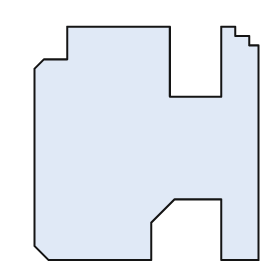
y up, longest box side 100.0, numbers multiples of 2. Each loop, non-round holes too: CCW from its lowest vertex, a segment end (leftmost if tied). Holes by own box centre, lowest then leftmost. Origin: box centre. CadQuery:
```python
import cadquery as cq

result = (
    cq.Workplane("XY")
    .moveTo(-42.0, -50.0)
    .lineTo(2.0, -50.0)
    .lineTo(2.0, -34.0)
    .lineTo(12.0, -24.0)
    .lineTo(32.0, -24.0)
    .lineTo(32.0, -50.0)
    .lineTo(48.0, -50.0)
    .lineTo(48.0, 42.0)
    .lineTo(44.0, 42.0)
    .lineTo(44.0, 46.0)
    .lineTo(38.0, 46.0)
    .lineTo(38.0, 50.0)
    .lineTo(32.0, 50.0)
    .lineTo(32.0, 20.0)
    .lineTo(10.0, 20.0)
    .lineTo(10.0, 50.0)
    .lineTo(-34.0, 50.0)
    .lineTo(-34.0, 36.0)
    .lineTo(-44.0, 36.0)
    .lineTo(-48.0, 32.0)
    .lineTo(-48.0, -44.0)
    .close()
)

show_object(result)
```